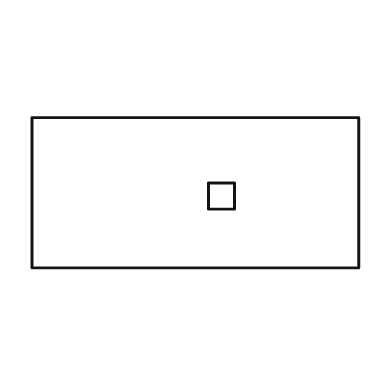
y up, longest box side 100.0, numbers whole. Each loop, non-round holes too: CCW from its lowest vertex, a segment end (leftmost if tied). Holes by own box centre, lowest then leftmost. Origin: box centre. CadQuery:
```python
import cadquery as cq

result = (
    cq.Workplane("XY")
    .moveTo(-50.0, -23.0)
    .lineTo(50.0, -23.0)
    .lineTo(50.0, 23.0)
    .lineTo(-50.0, 23.0)
    .close()
    .moveTo(4.0, -5.0)
    .lineTo(12.0, -5.0)
    .lineTo(12.0, 3.0)
    .lineTo(4.0, 3.0)
    .close()
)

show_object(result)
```